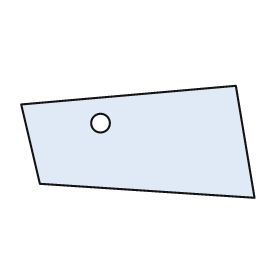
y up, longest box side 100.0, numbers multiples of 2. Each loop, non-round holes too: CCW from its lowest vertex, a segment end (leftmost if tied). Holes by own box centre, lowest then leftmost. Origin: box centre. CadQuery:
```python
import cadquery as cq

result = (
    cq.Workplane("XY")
    .moveTo(50.0, -24.0)
    .lineTo(42.0, 24.0)
    .lineTo(-50.0, 16.0)
    .lineTo(-42.0, -18.0)
    .close()
    .moveTo(-16.0, 8.0)
    .circle(4.0)
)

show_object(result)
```